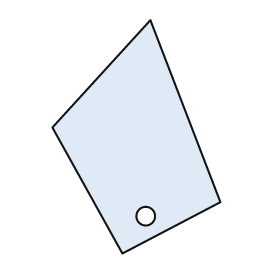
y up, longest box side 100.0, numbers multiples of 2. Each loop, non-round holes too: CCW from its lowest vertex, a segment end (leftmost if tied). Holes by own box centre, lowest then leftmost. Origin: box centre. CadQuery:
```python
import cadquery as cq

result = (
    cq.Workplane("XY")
    .moveTo(-6.0, -50.0)
    .lineTo(36.0, -28.0)
    .lineTo(6.0, 50.0)
    .lineTo(-36.0, 4.0)
    .close()
    .moveTo(4.0, -34.0)
    .circle(4.0)
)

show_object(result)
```